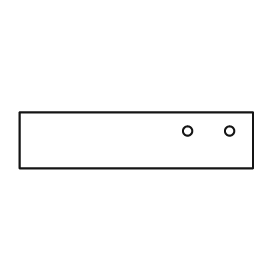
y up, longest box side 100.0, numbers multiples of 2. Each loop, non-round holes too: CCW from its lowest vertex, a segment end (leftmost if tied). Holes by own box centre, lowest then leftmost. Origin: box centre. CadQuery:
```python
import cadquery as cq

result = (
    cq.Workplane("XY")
    .moveTo(-50.0, -12.0)
    .lineTo(50.0, -12.0)
    .lineTo(50.0, 12.0)
    .lineTo(-50.0, 12.0)
    .close()
    .moveTo(22.0, 4.0)
    .circle(2.0)
    .moveTo(40.0, 4.0)
    .circle(2.0)
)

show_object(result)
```